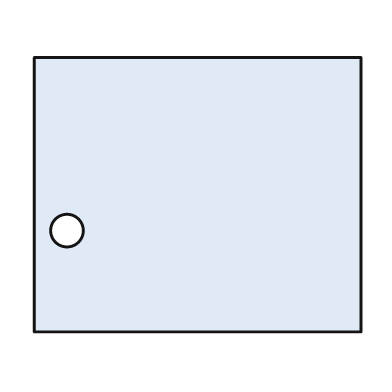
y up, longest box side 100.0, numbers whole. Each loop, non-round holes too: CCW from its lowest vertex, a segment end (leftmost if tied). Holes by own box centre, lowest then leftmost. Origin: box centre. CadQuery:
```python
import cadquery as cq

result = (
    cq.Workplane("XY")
    .moveTo(-50.0, -42.0)
    .lineTo(50.0, -42.0)
    .lineTo(50.0, 42.0)
    .lineTo(-50.0, 42.0)
    .close()
    .moveTo(-40.0, -11.0)
    .circle(5.0)
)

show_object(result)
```